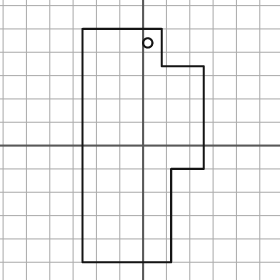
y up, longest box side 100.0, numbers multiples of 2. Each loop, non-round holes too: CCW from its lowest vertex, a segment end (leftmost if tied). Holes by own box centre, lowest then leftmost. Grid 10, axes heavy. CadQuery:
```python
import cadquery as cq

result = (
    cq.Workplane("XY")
    .moveTo(-26.0, -50.0)
    .lineTo(12.0, -50.0)
    .lineTo(12.0, -10.0)
    .lineTo(26.0, -10.0)
    .lineTo(26.0, 34.0)
    .lineTo(8.0, 34.0)
    .lineTo(8.0, 50.0)
    .lineTo(-26.0, 50.0)
    .close()
    .moveTo(2.0, 44.0)
    .circle(2.0)
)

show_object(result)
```